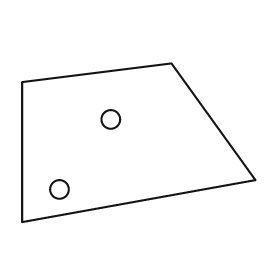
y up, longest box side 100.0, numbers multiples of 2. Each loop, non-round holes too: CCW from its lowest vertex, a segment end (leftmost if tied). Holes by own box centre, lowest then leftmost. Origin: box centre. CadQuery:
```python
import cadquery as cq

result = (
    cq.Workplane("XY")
    .moveTo(-50.0, -34.0)
    .lineTo(50.0, -16.0)
    .lineTo(14.0, 34.0)
    .lineTo(-50.0, 26.0)
    .close()
    .moveTo(-34.0, -20.0)
    .circle(4.0)
    .moveTo(-12.0, 10.0)
    .circle(4.0)
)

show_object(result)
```